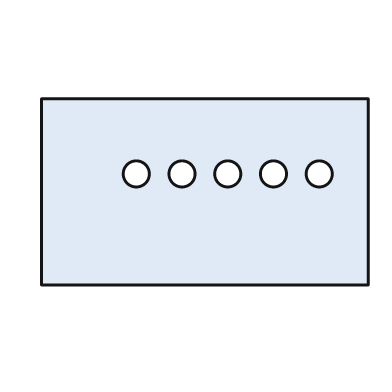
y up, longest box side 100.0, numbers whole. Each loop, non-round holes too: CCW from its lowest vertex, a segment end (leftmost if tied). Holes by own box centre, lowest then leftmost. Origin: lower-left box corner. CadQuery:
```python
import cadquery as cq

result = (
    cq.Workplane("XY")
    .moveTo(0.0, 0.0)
    .lineTo(100.0, 0.0)
    .lineTo(100.0, 57.0)
    .lineTo(0.0, 57.0)
    .close()
    .moveTo(29.0, 34.0)
    .circle(4.0)
    .moveTo(43.0, 34.0)
    .circle(4.0)
    .moveTo(57.0, 34.0)
    .circle(4.0)
    .moveTo(71.0, 34.0)
    .circle(4.0)
    .moveTo(85.0, 34.0)
    .circle(4.0)
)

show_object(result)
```